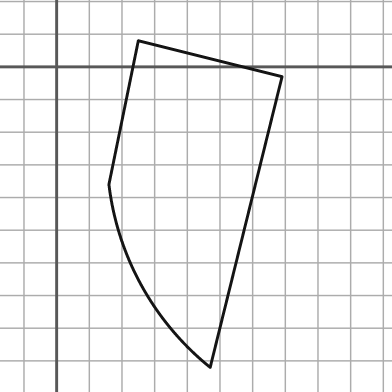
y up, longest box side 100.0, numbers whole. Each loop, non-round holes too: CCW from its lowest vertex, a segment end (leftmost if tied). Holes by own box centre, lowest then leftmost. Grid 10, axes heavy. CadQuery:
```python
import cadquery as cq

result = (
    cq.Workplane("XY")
    .moveTo(47.0, -92.0)
    .lineTo(69.0, -3.0)
    .lineTo(25.0, 8.0)
    .lineTo(16.0, -36.0)
    .threePointArc((26.0, -67.0), (47.0, -92.0))
    .close()
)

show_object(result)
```